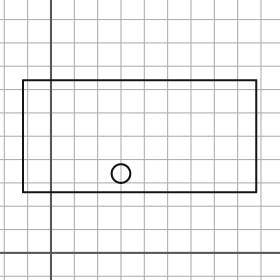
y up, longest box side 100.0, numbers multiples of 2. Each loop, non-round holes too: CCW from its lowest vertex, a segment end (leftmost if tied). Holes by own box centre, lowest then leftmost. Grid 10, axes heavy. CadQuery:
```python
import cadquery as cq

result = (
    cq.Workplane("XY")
    .moveTo(-12.0, 26.0)
    .lineTo(88.0, 26.0)
    .lineTo(88.0, 74.0)
    .lineTo(-12.0, 74.0)
    .close()
    .moveTo(30.0, 34.0)
    .circle(4.0)
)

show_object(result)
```